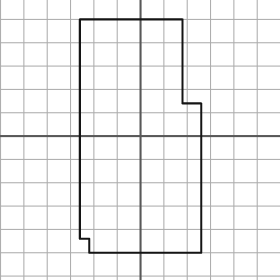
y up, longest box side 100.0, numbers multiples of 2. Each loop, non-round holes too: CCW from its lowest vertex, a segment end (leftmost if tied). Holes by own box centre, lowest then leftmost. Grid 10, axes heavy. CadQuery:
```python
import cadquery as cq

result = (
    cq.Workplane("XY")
    .moveTo(-22.0, -50.0)
    .lineTo(26.0, -50.0)
    .lineTo(26.0, 14.0)
    .lineTo(18.0, 14.0)
    .lineTo(18.0, 50.0)
    .lineTo(-26.0, 50.0)
    .lineTo(-26.0, -44.0)
    .lineTo(-22.0, -44.0)
    .close()
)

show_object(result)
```